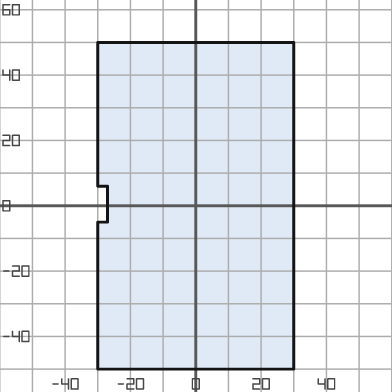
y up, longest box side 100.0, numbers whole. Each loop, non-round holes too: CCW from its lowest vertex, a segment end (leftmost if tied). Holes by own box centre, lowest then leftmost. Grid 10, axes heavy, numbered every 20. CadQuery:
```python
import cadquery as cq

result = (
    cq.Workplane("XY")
    .moveTo(-30.0, -50.0)
    .lineTo(30.0, -50.0)
    .lineTo(30.0, 50.0)
    .lineTo(-30.0, 50.0)
    .lineTo(-30.0, 6.0)
    .lineTo(-27.0, 6.0)
    .lineTo(-27.0, -5.0)
    .lineTo(-30.0, -5.0)
    .close()
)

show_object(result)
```